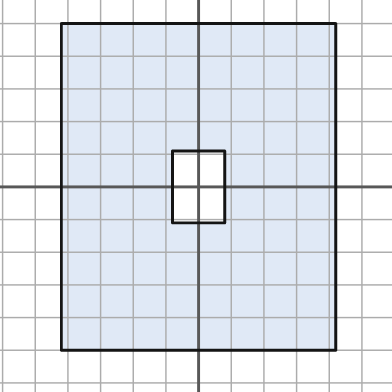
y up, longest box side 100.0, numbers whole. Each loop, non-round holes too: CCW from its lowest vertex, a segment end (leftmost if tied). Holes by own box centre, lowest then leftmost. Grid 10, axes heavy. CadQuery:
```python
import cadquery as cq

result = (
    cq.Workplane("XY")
    .moveTo(-42.0, -50.0)
    .lineTo(42.0, -50.0)
    .lineTo(42.0, 50.0)
    .lineTo(-42.0, 50.0)
    .close()
    .moveTo(-8.0, -11.0)
    .lineTo(8.0, -11.0)
    .lineTo(8.0, 11.0)
    .lineTo(-8.0, 11.0)
    .close()
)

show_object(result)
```